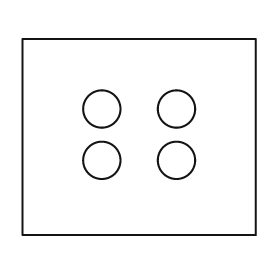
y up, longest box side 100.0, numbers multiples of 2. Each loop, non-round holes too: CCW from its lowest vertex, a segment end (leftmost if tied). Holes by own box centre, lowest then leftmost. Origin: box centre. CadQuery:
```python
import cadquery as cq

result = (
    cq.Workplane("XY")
    .moveTo(-50.0, -42.0)
    .lineTo(50.0, -42.0)
    .lineTo(50.0, 42.0)
    .lineTo(-50.0, 42.0)
    .close()
    .moveTo(-16.0, -10.0)
    .circle(8.0)
    .moveTo(16.0, -10.0)
    .circle(8.0)
    .moveTo(-16.0, 12.0)
    .circle(8.0)
    .moveTo(16.0, 12.0)
    .circle(8.0)
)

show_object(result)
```